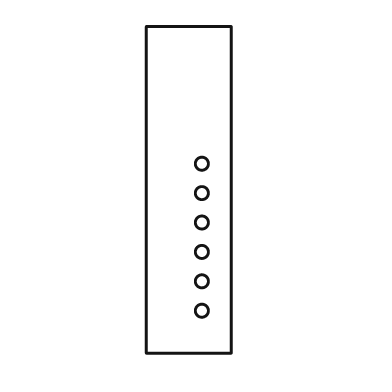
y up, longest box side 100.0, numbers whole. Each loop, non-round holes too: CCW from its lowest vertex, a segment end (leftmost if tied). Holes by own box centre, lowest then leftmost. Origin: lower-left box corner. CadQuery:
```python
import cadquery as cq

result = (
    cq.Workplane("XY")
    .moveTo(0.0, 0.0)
    .lineTo(26.0, 0.0)
    .lineTo(26.0, 100.0)
    .lineTo(0.0, 100.0)
    .close()
    .moveTo(17.0, 13.0)
    .circle(2.0)
    .moveTo(17.0, 22.0)
    .circle(2.0)
    .moveTo(17.0, 31.0)
    .circle(2.0)
    .moveTo(17.0, 40.0)
    .circle(2.0)
    .moveTo(17.0, 49.0)
    .circle(2.0)
    .moveTo(17.0, 58.0)
    .circle(2.0)
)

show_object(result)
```